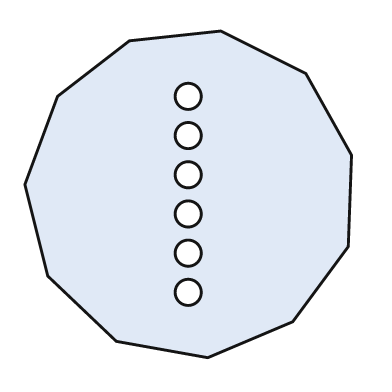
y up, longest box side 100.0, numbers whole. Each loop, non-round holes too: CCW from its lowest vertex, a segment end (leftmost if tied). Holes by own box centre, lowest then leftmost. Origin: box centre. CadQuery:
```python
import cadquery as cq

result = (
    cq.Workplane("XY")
    .moveTo(6.0, -50.0)
    .lineTo(32.0, -39.0)
    .lineTo(49.0, -16.0)
    .lineTo(50.0, 12.0)
    .lineTo(36.0, 37.0)
    .lineTo(10.0, 50.0)
    .lineTo(-18.0, 47.0)
    .lineTo(-40.0, 30.0)
    .lineTo(-50.0, 3.0)
    .lineTo(-43.0, -25.0)
    .lineTo(-22.0, -45.0)
    .close()
    .moveTo(0.0, -30.0)
    .circle(4.0)
    .moveTo(0.0, -18.0)
    .circle(4.0)
    .moveTo(0.0, -6.0)
    .circle(4.0)
    .moveTo(0.0, 6.0)
    .circle(4.0)
    .moveTo(0.0, 18.0)
    .circle(4.0)
    .moveTo(0.0, 30.0)
    .circle(4.0)
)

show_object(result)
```